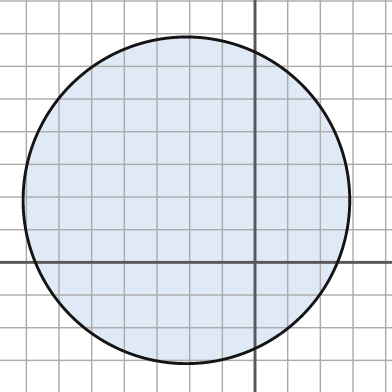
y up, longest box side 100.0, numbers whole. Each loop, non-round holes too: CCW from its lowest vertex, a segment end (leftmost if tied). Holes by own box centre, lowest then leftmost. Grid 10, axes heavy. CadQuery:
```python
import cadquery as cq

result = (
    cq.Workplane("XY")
    .moveTo(-21.0, 19.0)
    .circle(50.0)
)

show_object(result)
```